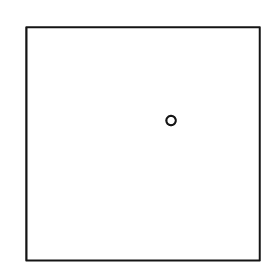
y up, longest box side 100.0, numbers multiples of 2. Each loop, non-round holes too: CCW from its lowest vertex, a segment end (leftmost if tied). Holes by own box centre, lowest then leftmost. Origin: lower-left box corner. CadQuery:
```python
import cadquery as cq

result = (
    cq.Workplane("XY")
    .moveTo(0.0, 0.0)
    .lineTo(100.0, 0.0)
    .lineTo(100.0, 100.0)
    .lineTo(0.0, 100.0)
    .close()
    .moveTo(62.0, 60.0)
    .circle(2.0)
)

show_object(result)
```